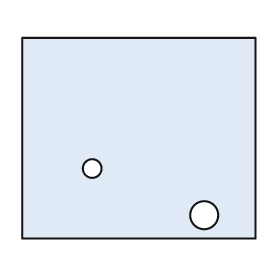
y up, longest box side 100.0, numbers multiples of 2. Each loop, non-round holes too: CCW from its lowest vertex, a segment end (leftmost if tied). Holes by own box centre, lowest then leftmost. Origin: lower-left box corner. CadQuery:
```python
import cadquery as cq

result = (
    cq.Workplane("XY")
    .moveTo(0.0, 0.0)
    .lineTo(100.0, 0.0)
    .lineTo(100.0, 86.0)
    .lineTo(0.0, 86.0)
    .close()
    .moveTo(78.0, 10.0)
    .circle(6.0)
    .moveTo(30.0, 30.0)
    .circle(4.0)
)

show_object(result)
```